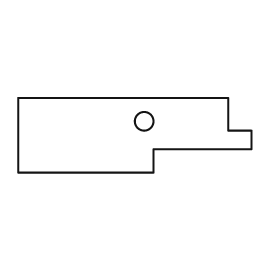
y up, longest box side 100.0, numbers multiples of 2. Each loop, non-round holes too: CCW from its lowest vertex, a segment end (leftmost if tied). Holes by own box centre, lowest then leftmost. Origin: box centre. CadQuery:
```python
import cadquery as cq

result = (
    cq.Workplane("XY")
    .moveTo(-50.0, -16.0)
    .lineTo(8.0, -16.0)
    .lineTo(8.0, -6.0)
    .lineTo(50.0, -6.0)
    .lineTo(50.0, 2.0)
    .lineTo(40.0, 2.0)
    .lineTo(40.0, 16.0)
    .lineTo(-50.0, 16.0)
    .close()
    .moveTo(4.0, 6.0)
    .circle(4.0)
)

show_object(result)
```